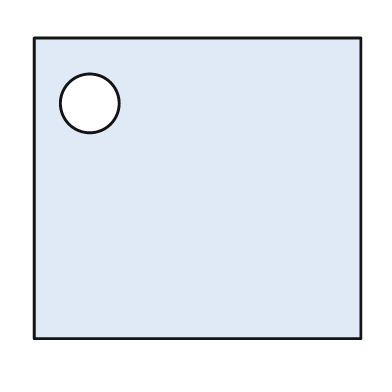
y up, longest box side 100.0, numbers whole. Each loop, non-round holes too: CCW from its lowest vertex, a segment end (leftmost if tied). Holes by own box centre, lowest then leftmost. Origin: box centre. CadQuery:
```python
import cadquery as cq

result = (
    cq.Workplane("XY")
    .moveTo(-50.0, -46.0)
    .lineTo(50.0, -46.0)
    .lineTo(50.0, 46.0)
    .lineTo(-50.0, 46.0)
    .close()
    .moveTo(-33.0, 26.0)
    .circle(9.0)
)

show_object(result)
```